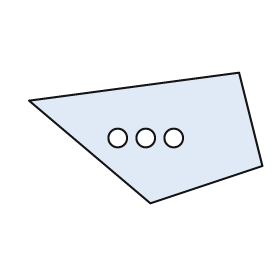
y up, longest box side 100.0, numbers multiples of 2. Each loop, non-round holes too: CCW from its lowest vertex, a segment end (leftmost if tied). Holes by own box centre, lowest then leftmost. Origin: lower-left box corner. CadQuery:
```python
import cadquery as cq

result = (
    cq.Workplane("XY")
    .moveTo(52.0, 0.0)
    .lineTo(100.0, 16.0)
    .lineTo(90.0, 56.0)
    .lineTo(0.0, 44.0)
    .close()
    .moveTo(38.0, 28.0)
    .circle(4.0)
    .moveTo(50.0, 28.0)
    .circle(4.0)
    .moveTo(62.0, 28.0)
    .circle(4.0)
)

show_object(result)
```